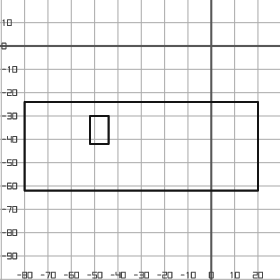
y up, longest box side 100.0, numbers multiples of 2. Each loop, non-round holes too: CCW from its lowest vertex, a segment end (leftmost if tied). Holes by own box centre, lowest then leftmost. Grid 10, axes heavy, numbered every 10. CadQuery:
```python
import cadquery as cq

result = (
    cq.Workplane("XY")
    .moveTo(-80.0, -62.0)
    .lineTo(20.0, -62.0)
    .lineTo(20.0, -24.0)
    .lineTo(-80.0, -24.0)
    .close()
    .moveTo(-52.0, -42.0)
    .lineTo(-44.0, -42.0)
    .lineTo(-44.0, -30.0)
    .lineTo(-52.0, -30.0)
    .close()
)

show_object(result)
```